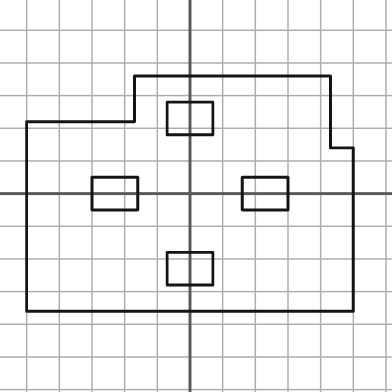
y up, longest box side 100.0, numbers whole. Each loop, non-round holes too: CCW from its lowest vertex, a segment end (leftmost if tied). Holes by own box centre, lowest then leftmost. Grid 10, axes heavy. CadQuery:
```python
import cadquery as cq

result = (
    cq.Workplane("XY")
    .moveTo(-50.0, -36.0)
    .lineTo(50.0, -36.0)
    .lineTo(50.0, 14.0)
    .lineTo(43.0, 14.0)
    .lineTo(43.0, 36.0)
    .lineTo(-17.0, 36.0)
    .lineTo(-17.0, 22.0)
    .lineTo(-50.0, 22.0)
    .close()
    .moveTo(-7.0, -28.0)
    .lineTo(7.0, -28.0)
    .lineTo(7.0, -18.0)
    .lineTo(-7.0, -18.0)
    .close()
    .moveTo(-30.0, -5.0)
    .lineTo(-16.0, -5.0)
    .lineTo(-16.0, 5.0)
    .lineTo(-30.0, 5.0)
    .close()
    .moveTo(16.0, -5.0)
    .lineTo(30.0, -5.0)
    .lineTo(30.0, 5.0)
    .lineTo(16.0, 5.0)
    .close()
    .moveTo(-7.0, 18.0)
    .lineTo(7.0, 18.0)
    .lineTo(7.0, 28.0)
    .lineTo(-7.0, 28.0)
    .close()
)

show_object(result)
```